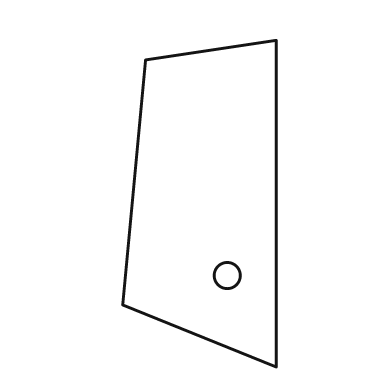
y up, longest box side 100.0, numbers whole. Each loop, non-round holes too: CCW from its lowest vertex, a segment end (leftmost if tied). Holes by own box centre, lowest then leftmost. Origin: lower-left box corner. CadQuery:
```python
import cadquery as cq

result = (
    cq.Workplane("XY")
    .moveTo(47.0, 0.0)
    .lineTo(47.0, 100.0)
    .lineTo(7.0, 94.0)
    .lineTo(0.0, 19.0)
    .close()
    .moveTo(32.0, 28.0)
    .circle(4.0)
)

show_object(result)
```